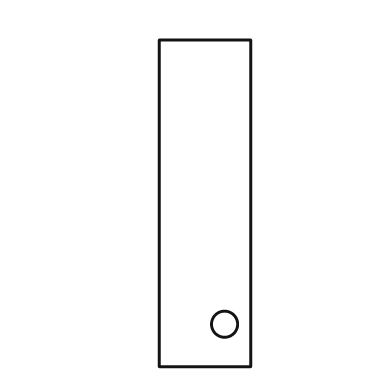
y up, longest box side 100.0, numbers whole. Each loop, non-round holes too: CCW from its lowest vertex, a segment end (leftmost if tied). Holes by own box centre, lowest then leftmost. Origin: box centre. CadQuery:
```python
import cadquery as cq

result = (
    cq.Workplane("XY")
    .moveTo(-14.0, -50.0)
    .lineTo(14.0, -50.0)
    .lineTo(14.0, 50.0)
    .lineTo(-14.0, 50.0)
    .close()
    .moveTo(6.0, -37.0)
    .circle(4.0)
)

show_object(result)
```